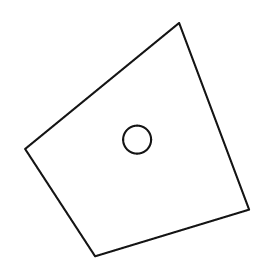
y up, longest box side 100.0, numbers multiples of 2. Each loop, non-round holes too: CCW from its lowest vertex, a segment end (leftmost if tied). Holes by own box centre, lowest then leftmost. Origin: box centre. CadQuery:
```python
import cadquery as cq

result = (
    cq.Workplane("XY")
    .moveTo(-18.0, -50.0)
    .lineTo(48.0, -30.0)
    .lineTo(18.0, 50.0)
    .lineTo(-48.0, -4.0)
    .close()
    .moveTo(0.0, 0.0)
    .circle(6.0)
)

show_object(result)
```